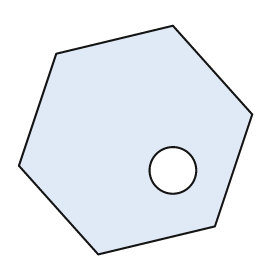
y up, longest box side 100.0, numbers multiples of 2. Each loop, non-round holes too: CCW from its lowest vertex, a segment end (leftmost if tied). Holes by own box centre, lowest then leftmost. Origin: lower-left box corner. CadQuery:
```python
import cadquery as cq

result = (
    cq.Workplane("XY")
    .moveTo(34.0, 0.0)
    .lineTo(84.0, 12.0)
    .lineTo(100.0, 60.0)
    .lineTo(66.0, 98.0)
    .lineTo(16.0, 86.0)
    .lineTo(0.0, 38.0)
    .close()
    .moveTo(66.0, 36.0)
    .circle(10.0)
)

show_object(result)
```